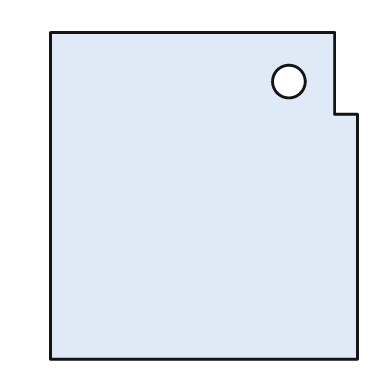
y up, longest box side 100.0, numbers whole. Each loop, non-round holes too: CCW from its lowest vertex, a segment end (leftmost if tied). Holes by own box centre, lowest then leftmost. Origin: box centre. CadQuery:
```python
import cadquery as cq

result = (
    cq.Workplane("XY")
    .moveTo(-47.0, -50.0)
    .lineTo(47.0, -50.0)
    .lineTo(47.0, 25.0)
    .lineTo(40.0, 25.0)
    .lineTo(40.0, 50.0)
    .lineTo(-47.0, 50.0)
    .close()
    .moveTo(26.0, 35.0)
    .circle(5.0)
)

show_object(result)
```